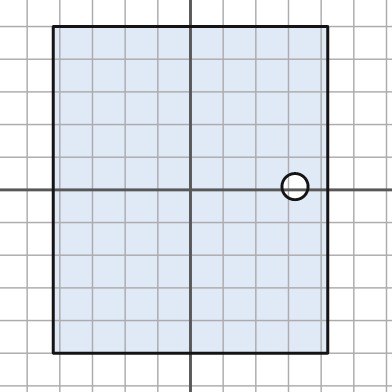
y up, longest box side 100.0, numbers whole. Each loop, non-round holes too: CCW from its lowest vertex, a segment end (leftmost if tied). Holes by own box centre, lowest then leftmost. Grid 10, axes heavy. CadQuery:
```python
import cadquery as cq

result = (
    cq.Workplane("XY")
    .moveTo(-42.0, -50.0)
    .lineTo(42.0, -50.0)
    .lineTo(42.0, 50.0)
    .lineTo(-42.0, 50.0)
    .close()
    .moveTo(32.0, 1.0)
    .circle(4.0)
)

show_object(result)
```